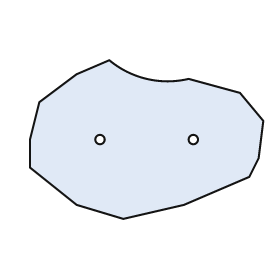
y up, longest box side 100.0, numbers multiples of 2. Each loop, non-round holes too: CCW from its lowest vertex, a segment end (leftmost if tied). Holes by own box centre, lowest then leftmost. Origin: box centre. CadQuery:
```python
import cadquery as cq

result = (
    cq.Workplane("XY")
    .moveTo(-10.0, -34.0)
    .lineTo(16.0, -28.0)
    .lineTo(44.0, -16.0)
    .lineTo(48.0, -8.0)
    .lineTo(50.0, 8.0)
    .lineTo(40.0, 20.0)
    .lineTo(18.0, 26.0)
    .threePointArc((0.0, 26.0), (-16.0, 34.0))
    .lineTo(-30.0, 28.0)
    .lineTo(-46.0, 16.0)
    .lineTo(-50.0, 0.0)
    .lineTo(-50.0, -12.0)
    .lineTo(-30.0, -28.0)
    .close()
    .moveTo(-20.0, 0.0)
    .circle(2.0)
    .moveTo(20.0, 0.0)
    .circle(2.0)
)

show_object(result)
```